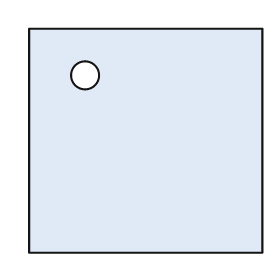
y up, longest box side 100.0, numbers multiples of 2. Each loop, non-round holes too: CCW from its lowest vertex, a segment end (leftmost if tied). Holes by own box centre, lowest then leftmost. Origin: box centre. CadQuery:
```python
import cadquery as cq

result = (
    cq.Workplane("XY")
    .moveTo(-50.0, -48.0)
    .lineTo(50.0, -48.0)
    .lineTo(50.0, 48.0)
    .lineTo(-50.0, 48.0)
    .close()
    .moveTo(-26.0, 28.0)
    .circle(6.0)
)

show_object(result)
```